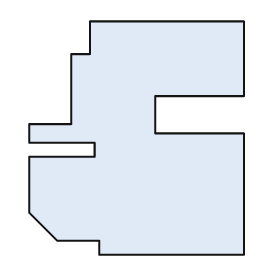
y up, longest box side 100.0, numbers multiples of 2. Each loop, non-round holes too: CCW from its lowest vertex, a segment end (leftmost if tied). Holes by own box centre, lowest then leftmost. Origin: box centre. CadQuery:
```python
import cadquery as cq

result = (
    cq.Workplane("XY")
    .moveTo(-16.0, -50.0)
    .lineTo(46.0, -50.0)
    .lineTo(46.0, 2.0)
    .lineTo(8.0, 2.0)
    .lineTo(8.0, 18.0)
    .lineTo(46.0, 18.0)
    .lineTo(46.0, 50.0)
    .lineTo(-20.0, 50.0)
    .lineTo(-20.0, 36.0)
    .lineTo(-28.0, 36.0)
    .lineTo(-28.0, 6.0)
    .lineTo(-46.0, 6.0)
    .lineTo(-46.0, -2.0)
    .lineTo(-18.0, -2.0)
    .lineTo(-18.0, -8.0)
    .lineTo(-46.0, -8.0)
    .lineTo(-46.0, -32.0)
    .lineTo(-34.0, -44.0)
    .lineTo(-16.0, -44.0)
    .close()
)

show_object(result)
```